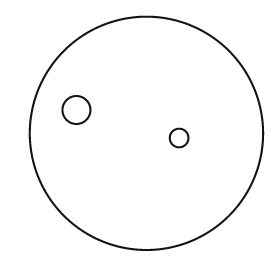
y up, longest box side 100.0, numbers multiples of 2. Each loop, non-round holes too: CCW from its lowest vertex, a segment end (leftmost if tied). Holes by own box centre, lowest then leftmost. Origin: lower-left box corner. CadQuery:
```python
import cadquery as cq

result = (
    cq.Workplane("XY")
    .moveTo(50.0, 50.0)
    .circle(50.0)
    .moveTo(64.0, 48.0)
    .circle(4.0)
    .moveTo(20.0, 60.0)
    .circle(6.0)
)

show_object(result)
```